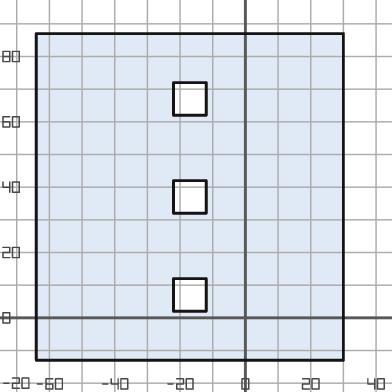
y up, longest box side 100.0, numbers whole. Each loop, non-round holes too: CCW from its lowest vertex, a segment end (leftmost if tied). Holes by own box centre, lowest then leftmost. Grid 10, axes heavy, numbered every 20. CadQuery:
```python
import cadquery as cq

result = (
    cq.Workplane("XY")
    .moveTo(-64.0, -13.0)
    .lineTo(30.0, -13.0)
    .lineTo(30.0, 87.0)
    .lineTo(-64.0, 87.0)
    .close()
    .moveTo(-22.0, 2.0)
    .lineTo(-12.0, 2.0)
    .lineTo(-12.0, 12.0)
    .lineTo(-22.0, 12.0)
    .close()
    .moveTo(-22.0, 32.0)
    .lineTo(-12.0, 32.0)
    .lineTo(-12.0, 42.0)
    .lineTo(-22.0, 42.0)
    .close()
    .moveTo(-22.0, 62.0)
    .lineTo(-12.0, 62.0)
    .lineTo(-12.0, 72.0)
    .lineTo(-22.0, 72.0)
    .close()
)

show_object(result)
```